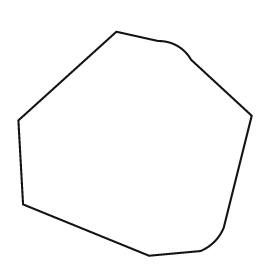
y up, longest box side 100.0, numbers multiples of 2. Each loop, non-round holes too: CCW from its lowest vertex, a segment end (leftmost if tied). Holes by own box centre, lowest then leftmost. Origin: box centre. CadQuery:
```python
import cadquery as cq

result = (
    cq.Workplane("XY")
    .moveTo(6.0, -48.0)
    .lineTo(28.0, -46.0)
    .threePointArc((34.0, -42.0), (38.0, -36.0))
    .lineTo(50.0, 12.0)
    .lineTo(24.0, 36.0)
    .threePointArc((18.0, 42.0), (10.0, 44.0))
    .lineTo(-8.0, 48.0)
    .lineTo(-50.0, 10.0)
    .lineTo(-48.0, -26.0)
    .close()
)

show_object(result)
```